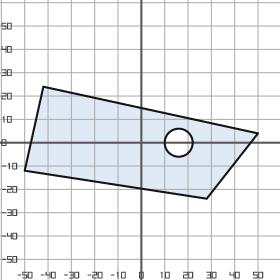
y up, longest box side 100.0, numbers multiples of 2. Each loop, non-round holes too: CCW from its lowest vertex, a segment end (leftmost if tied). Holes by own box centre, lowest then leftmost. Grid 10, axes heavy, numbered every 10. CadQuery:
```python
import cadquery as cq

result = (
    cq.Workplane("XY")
    .moveTo(28.0, -24.0)
    .lineTo(50.0, 4.0)
    .lineTo(-42.0, 24.0)
    .lineTo(-50.0, -12.0)
    .close()
    .moveTo(16.0, 0.0)
    .circle(6.0)
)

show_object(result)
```